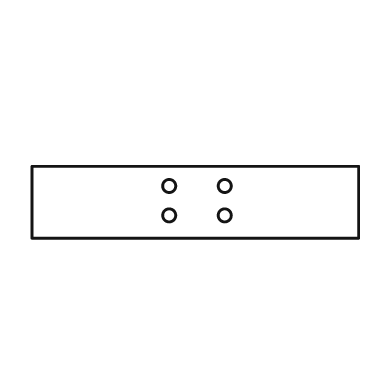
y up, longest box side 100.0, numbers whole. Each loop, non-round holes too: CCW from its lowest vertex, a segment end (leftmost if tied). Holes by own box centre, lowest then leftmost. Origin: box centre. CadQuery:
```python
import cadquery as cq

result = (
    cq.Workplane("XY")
    .moveTo(-50.0, -11.0)
    .lineTo(50.0, -11.0)
    .lineTo(50.0, 11.0)
    .lineTo(-50.0, 11.0)
    .close()
    .moveTo(-8.0, -4.0)
    .circle(2.0)
    .moveTo(9.0, -4.0)
    .circle(2.0)
    .moveTo(-8.0, 5.0)
    .circle(2.0)
    .moveTo(9.0, 5.0)
    .circle(2.0)
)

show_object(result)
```